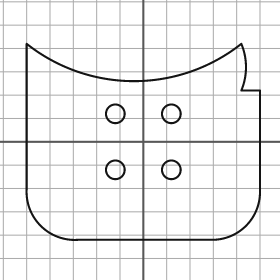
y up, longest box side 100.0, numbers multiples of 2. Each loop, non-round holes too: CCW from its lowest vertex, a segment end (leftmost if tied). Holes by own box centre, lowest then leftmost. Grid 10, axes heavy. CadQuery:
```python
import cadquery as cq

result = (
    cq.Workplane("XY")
    .moveTo(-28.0, -42.0)
    .lineTo(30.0, -42.0)
    .threePointArc((44.0, -36.0), (50.0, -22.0))
    .lineTo(50.0, 22.0)
    .lineTo(42.0, 22.0)
    .threePointArc((44.0, 32.0), (42.0, 42.0))
    .threePointArc((-4.0, 26.0), (-50.0, 42.0))
    .lineTo(-50.0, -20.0)
    .threePointArc((-44.0, -36.0), (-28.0, -42.0))
    .close()
    .moveTo(-12.0, -12.0)
    .circle(4.0)
    .moveTo(12.0, -12.0)
    .circle(4.0)
    .moveTo(-12.0, 12.0)
    .circle(4.0)
    .moveTo(12.0, 12.0)
    .circle(4.0)
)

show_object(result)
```